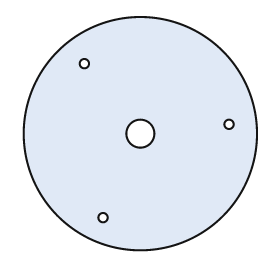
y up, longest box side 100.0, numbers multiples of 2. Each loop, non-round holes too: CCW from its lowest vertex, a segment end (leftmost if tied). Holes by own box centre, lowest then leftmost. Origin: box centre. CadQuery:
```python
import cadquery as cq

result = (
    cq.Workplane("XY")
    .moveTo(0.0, 0.0)
    .circle(50.0)
    .moveTo(-16.0, -36.0)
    .circle(2.0)
    .moveTo(0.0, 0.0)
    .circle(6.0)
    .moveTo(38.0, 4.0)
    .circle(2.0)
    .moveTo(-24.0, 30.0)
    .circle(2.0)
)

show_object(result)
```